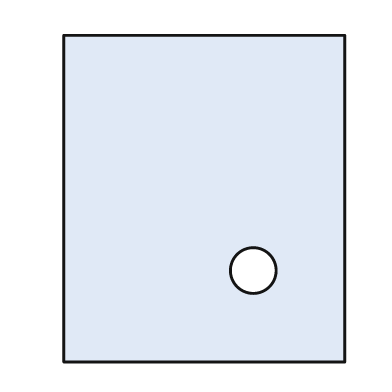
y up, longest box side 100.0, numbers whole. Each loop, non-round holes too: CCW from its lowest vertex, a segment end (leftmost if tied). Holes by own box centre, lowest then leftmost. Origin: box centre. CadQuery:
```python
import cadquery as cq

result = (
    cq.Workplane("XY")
    .moveTo(-43.0, -50.0)
    .lineTo(43.0, -50.0)
    .lineTo(43.0, 50.0)
    .lineTo(-43.0, 50.0)
    .close()
    .moveTo(15.0, -22.0)
    .circle(7.0)
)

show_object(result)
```